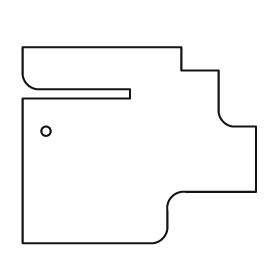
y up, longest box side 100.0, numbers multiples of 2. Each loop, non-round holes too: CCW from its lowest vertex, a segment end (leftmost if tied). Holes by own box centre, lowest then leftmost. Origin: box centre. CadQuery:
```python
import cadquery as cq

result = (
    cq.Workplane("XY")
    .moveTo(-50.0, -42.0)
    .lineTo(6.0, -42.0)
    .threePointArc((10.0, -40.0), (12.0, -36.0))
    .lineTo(12.0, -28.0)
    .threePointArc((14.0, -22.0), (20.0, -20.0))
    .lineTo(50.0, -20.0)
    .lineTo(50.0, 8.0)
    .lineTo(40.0, 8.0)
    .threePointArc((36.0, 10.0), (34.0, 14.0))
    .lineTo(34.0, 32.0)
    .lineTo(18.0, 32.0)
    .lineTo(18.0, 42.0)
    .lineTo(-50.0, 42.0)
    .lineTo(-50.0, 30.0)
    .threePointArc((-48.0, 26.0), (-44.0, 24.0))
    .lineTo(-4.0, 24.0)
    .lineTo(-4.0, 20.0)
    .lineTo(-50.0, 20.0)
    .close()
    .moveTo(-40.0, 6.0)
    .circle(2.0)
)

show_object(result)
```